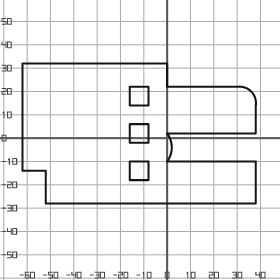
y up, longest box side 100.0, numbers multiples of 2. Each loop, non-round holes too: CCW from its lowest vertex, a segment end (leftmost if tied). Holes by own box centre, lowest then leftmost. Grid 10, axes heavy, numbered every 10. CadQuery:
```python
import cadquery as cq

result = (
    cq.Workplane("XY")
    .moveTo(-52.0, -28.0)
    .lineTo(38.0, -28.0)
    .lineTo(38.0, -10.0)
    .lineTo(0.0, -10.0)
    .threePointArc((2.0, -4.0), (0.0, 2.0))
    .lineTo(38.0, 2.0)
    .lineTo(38.0, 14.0)
    .threePointArc((36.0, 20.0), (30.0, 22.0))
    .lineTo(0.0, 22.0)
    .lineTo(0.0, 32.0)
    .lineTo(-62.0, 32.0)
    .lineTo(-62.0, -14.0)
    .lineTo(-52.0, -14.0)
    .close()
    .moveTo(-16.0, -18.0)
    .lineTo(-8.0, -18.0)
    .lineTo(-8.0, -10.0)
    .lineTo(-16.0, -10.0)
    .close()
    .moveTo(-16.0, -2.0)
    .lineTo(-8.0, -2.0)
    .lineTo(-8.0, 6.0)
    .lineTo(-16.0, 6.0)
    .close()
    .moveTo(-16.0, 14.0)
    .lineTo(-8.0, 14.0)
    .lineTo(-8.0, 22.0)
    .lineTo(-16.0, 22.0)
    .close()
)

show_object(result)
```